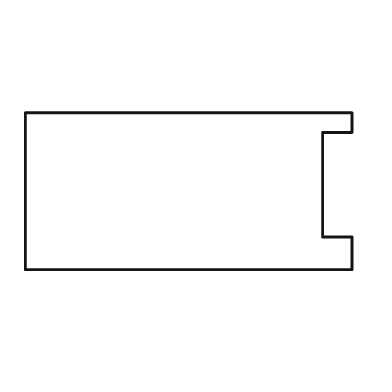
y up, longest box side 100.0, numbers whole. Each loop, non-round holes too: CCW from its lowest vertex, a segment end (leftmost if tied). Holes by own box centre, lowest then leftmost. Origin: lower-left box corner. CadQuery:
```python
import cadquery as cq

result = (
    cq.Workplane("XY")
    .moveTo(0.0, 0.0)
    .lineTo(100.0, 0.0)
    .lineTo(100.0, 10.0)
    .lineTo(91.0, 10.0)
    .lineTo(91.0, 42.0)
    .lineTo(100.0, 42.0)
    .lineTo(100.0, 48.0)
    .lineTo(0.0, 48.0)
    .close()
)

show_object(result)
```